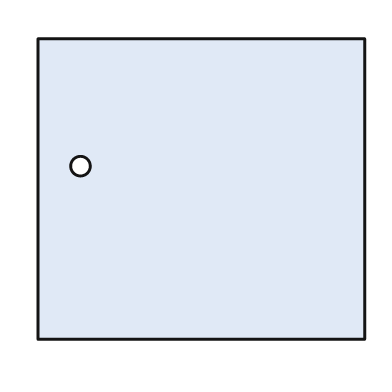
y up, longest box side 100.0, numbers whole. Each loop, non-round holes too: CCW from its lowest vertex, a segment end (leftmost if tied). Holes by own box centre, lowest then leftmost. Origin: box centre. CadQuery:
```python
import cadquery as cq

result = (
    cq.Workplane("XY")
    .moveTo(-50.0, -46.0)
    .lineTo(50.0, -46.0)
    .lineTo(50.0, 46.0)
    .lineTo(-50.0, 46.0)
    .close()
    .moveTo(-37.0, 7.0)
    .circle(3.0)
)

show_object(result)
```